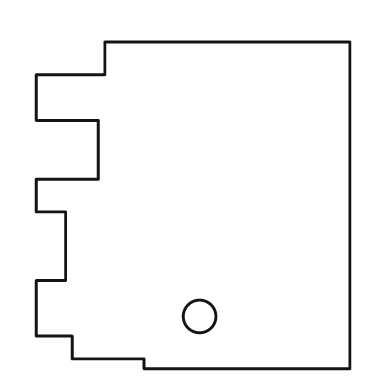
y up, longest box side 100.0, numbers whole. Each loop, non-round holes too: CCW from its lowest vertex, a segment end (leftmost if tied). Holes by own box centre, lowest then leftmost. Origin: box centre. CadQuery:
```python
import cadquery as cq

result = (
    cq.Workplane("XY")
    .moveTo(-15.0, -50.0)
    .lineTo(48.0, -50.0)
    .lineTo(48.0, 50.0)
    .lineTo(-27.0, 50.0)
    .lineTo(-27.0, 40.0)
    .lineTo(-48.0, 40.0)
    .lineTo(-48.0, 26.0)
    .lineTo(-29.0, 26.0)
    .lineTo(-29.0, 8.0)
    .lineTo(-48.0, 8.0)
    .lineTo(-48.0, -2.0)
    .lineTo(-39.0, -2.0)
    .lineTo(-39.0, -23.0)
    .lineTo(-48.0, -23.0)
    .lineTo(-48.0, -40.0)
    .lineTo(-37.0, -40.0)
    .lineTo(-37.0, -47.0)
    .lineTo(-15.0, -47.0)
    .close()
    .moveTo(2.0, -34.0)
    .circle(5.0)
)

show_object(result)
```